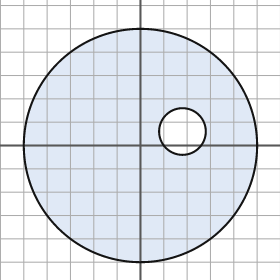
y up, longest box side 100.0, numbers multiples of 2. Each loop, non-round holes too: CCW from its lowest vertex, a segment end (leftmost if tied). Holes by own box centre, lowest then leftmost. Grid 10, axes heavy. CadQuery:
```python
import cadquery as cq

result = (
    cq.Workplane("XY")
    .moveTo(0.0, 0.0)
    .circle(50.0)
    .moveTo(18.0, 6.0)
    .circle(10.0)
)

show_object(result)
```